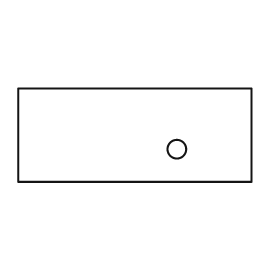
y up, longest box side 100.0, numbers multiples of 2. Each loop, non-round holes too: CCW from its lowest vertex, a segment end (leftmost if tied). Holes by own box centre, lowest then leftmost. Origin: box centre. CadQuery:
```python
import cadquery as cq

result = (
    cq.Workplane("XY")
    .moveTo(-50.0, -20.0)
    .lineTo(50.0, -20.0)
    .lineTo(50.0, 20.0)
    .lineTo(-50.0, 20.0)
    .close()
    .moveTo(18.0, -6.0)
    .circle(4.0)
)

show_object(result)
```